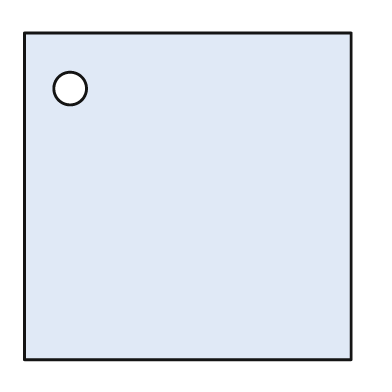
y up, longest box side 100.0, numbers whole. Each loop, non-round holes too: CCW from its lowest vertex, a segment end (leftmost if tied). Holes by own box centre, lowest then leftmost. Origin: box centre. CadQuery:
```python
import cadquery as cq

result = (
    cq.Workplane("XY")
    .moveTo(-50.0, -50.0)
    .lineTo(50.0, -50.0)
    .lineTo(50.0, 50.0)
    .lineTo(-50.0, 50.0)
    .close()
    .moveTo(-36.0, 33.0)
    .circle(5.0)
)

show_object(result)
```